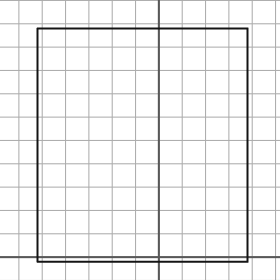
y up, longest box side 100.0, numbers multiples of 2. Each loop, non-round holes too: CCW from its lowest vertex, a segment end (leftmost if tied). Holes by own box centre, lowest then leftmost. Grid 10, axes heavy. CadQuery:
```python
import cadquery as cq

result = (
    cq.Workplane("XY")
    .moveTo(-52.0, -2.0)
    .lineTo(38.0, -2.0)
    .lineTo(38.0, 98.0)
    .lineTo(-52.0, 98.0)
    .close()
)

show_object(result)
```